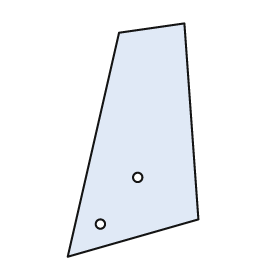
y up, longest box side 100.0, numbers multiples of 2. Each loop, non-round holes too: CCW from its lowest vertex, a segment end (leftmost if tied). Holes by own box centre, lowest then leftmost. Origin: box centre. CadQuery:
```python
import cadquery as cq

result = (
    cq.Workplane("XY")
    .moveTo(-28.0, -50.0)
    .lineTo(28.0, -34.0)
    .lineTo(22.0, 50.0)
    .lineTo(-6.0, 46.0)
    .close()
    .moveTo(-14.0, -36.0)
    .circle(2.0)
    .moveTo(2.0, -16.0)
    .circle(2.0)
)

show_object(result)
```